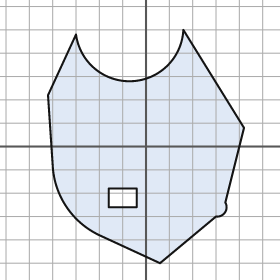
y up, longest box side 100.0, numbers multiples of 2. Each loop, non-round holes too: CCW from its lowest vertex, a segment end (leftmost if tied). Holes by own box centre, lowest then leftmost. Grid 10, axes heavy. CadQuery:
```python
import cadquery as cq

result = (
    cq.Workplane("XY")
    .moveTo(6.0, -50.0)
    .lineTo(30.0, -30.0)
    .threePointArc((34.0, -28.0), (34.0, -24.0))
    .lineTo(42.0, 8.0)
    .lineTo(16.0, 50.0)
    .threePointArc((-6.0, 28.0), (-30.0, 48.0))
    .lineTo(-42.0, 22.0)
    .lineTo(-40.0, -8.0)
    .threePointArc((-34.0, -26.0), (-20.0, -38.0))
    .close()
    .moveTo(-16.0, -26.0)
    .lineTo(-4.0, -26.0)
    .lineTo(-4.0, -18.0)
    .lineTo(-16.0, -18.0)
    .close()
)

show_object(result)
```